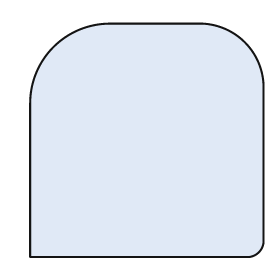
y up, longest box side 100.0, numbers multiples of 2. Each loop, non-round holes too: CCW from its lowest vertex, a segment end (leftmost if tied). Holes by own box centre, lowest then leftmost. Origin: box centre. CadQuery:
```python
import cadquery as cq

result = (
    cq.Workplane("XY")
    .moveTo(-50.0, -50.0)
    .lineTo(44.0, -50.0)
    .threePointArc((48.0, -48.0), (50.0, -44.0))
    .lineTo(50.0, 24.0)
    .threePointArc((42.0, 42.0), (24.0, 50.0))
    .lineTo(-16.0, 50.0)
    .threePointArc((-40.0, 40.0), (-50.0, 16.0))
    .close()
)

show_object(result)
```